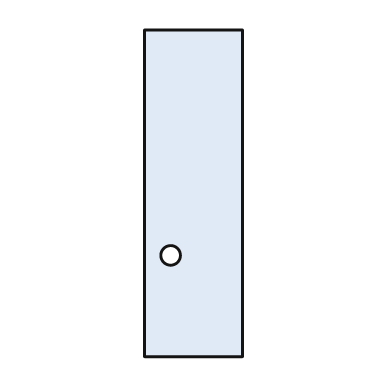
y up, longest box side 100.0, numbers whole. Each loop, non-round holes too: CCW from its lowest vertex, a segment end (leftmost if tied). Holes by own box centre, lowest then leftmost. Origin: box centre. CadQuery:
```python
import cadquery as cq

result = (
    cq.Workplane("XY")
    .moveTo(-15.0, -50.0)
    .lineTo(15.0, -50.0)
    .lineTo(15.0, 50.0)
    .lineTo(-15.0, 50.0)
    .close()
    .moveTo(-7.0, -19.0)
    .circle(3.0)
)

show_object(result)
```